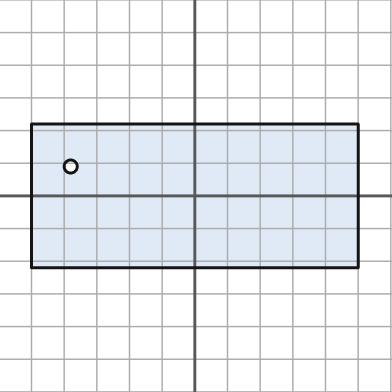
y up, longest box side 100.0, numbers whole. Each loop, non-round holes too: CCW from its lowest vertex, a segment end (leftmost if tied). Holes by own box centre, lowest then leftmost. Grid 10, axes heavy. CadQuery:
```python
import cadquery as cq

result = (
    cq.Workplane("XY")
    .moveTo(-50.0, -22.0)
    .lineTo(50.0, -22.0)
    .lineTo(50.0, 22.0)
    .lineTo(-50.0, 22.0)
    .close()
    .moveTo(-38.0, 9.0)
    .circle(2.0)
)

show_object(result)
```